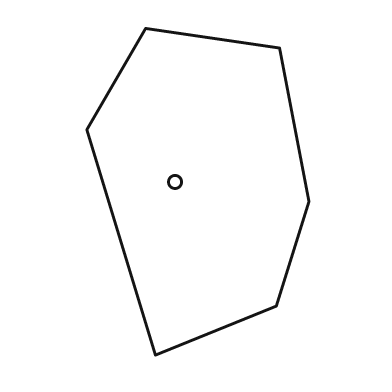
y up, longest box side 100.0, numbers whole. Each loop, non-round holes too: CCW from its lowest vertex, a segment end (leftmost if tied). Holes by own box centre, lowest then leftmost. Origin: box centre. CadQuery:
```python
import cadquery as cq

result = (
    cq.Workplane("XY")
    .moveTo(-13.0, -50.0)
    .lineTo(24.0, -35.0)
    .lineTo(34.0, -3.0)
    .lineTo(25.0, 44.0)
    .lineTo(-16.0, 50.0)
    .lineTo(-34.0, 19.0)
    .close()
    .moveTo(-7.0, 3.0)
    .circle(2.0)
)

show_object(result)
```